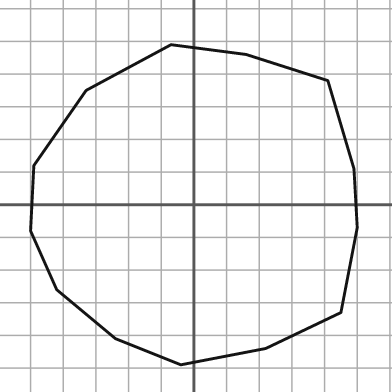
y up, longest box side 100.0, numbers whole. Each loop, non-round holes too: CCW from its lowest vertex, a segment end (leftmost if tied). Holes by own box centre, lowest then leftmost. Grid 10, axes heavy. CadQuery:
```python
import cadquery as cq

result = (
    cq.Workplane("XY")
    .moveTo(-4.0, -49.0)
    .lineTo(22.0, -44.0)
    .lineTo(45.0, -33.0)
    .lineTo(50.0, -7.0)
    .lineTo(49.0, 11.0)
    .lineTo(41.0, 38.0)
    .lineTo(16.0, 46.0)
    .lineTo(-7.0, 49.0)
    .lineTo(-33.0, 35.0)
    .lineTo(-49.0, 12.0)
    .lineTo(-50.0, -8.0)
    .lineTo(-42.0, -26.0)
    .lineTo(-24.0, -41.0)
    .close()
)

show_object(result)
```